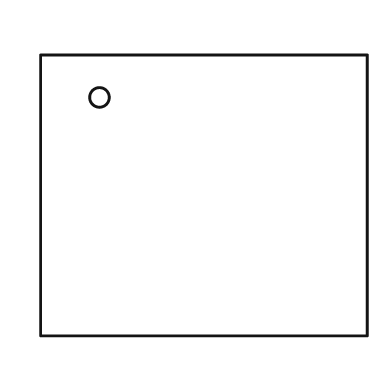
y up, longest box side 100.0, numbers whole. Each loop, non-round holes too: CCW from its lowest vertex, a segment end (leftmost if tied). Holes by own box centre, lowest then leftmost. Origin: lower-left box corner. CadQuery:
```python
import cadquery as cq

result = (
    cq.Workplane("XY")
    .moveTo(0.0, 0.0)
    .lineTo(100.0, 0.0)
    .lineTo(100.0, 86.0)
    .lineTo(0.0, 86.0)
    .close()
    .moveTo(18.0, 73.0)
    .circle(3.0)
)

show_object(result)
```